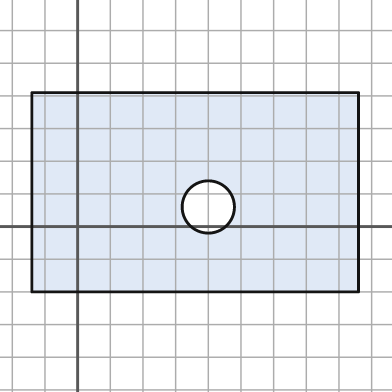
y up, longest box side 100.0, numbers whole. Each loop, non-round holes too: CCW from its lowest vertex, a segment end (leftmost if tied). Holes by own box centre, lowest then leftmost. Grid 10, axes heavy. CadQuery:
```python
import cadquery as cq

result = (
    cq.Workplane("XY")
    .moveTo(-14.0, -20.0)
    .lineTo(86.0, -20.0)
    .lineTo(86.0, 41.0)
    .lineTo(-14.0, 41.0)
    .close()
    .moveTo(40.0, 6.0)
    .circle(8.0)
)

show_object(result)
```